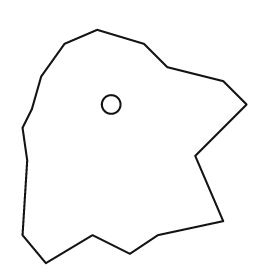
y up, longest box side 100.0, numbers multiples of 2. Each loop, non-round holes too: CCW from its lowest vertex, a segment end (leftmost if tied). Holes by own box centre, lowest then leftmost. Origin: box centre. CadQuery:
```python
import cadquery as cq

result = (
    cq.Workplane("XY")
    .moveTo(-38.0, -50.0)
    .lineTo(-18.0, -38.0)
    .lineTo(-2.0, -46.0)
    .lineTo(10.0, -38.0)
    .lineTo(38.0, -32.0)
    .lineTo(26.0, -4.0)
    .lineTo(48.0, 18.0)
    .lineTo(38.0, 28.0)
    .lineTo(14.0, 34.0)
    .lineTo(4.0, 44.0)
    .lineTo(-16.0, 50.0)
    .lineTo(-30.0, 44.0)
    .lineTo(-40.0, 30.0)
    .lineTo(-44.0, 16.0)
    .lineTo(-48.0, 8.0)
    .lineTo(-46.0, -6.0)
    .lineTo(-48.0, -38.0)
    .close()
    .moveTo(-10.0, 18.0)
    .circle(4.0)
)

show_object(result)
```